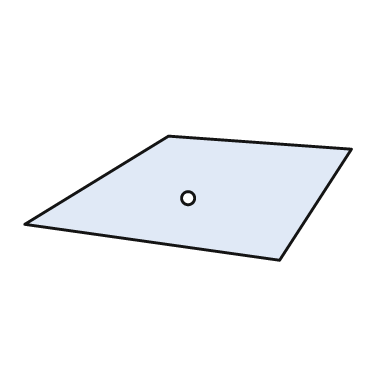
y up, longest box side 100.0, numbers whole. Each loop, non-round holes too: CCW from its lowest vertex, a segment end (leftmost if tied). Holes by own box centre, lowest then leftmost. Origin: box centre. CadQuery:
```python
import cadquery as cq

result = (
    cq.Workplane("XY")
    .moveTo(28.0, -19.0)
    .lineTo(50.0, 15.0)
    .lineTo(-6.0, 19.0)
    .lineTo(-50.0, -8.0)
    .close()
    .moveTo(0.0, 0.0)
    .circle(2.0)
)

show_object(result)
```